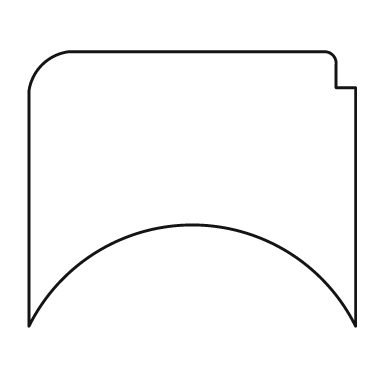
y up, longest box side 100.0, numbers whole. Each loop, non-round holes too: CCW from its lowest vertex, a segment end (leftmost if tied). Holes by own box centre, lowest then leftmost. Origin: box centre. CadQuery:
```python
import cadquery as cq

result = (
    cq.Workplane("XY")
    .moveTo(-50.0, -42.0)
    .threePointArc((0.0, -11.0), (50.0, -42.0))
    .lineTo(50.0, 31.0)
    .lineTo(44.0, 31.0)
    .lineTo(44.0, 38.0)
    .threePointArc((43.0, 41.0), (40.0, 42.0))
    .lineTo(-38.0, 42.0)
    .threePointArc((-46.0, 38.0), (-50.0, 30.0))
    .close()
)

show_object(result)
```